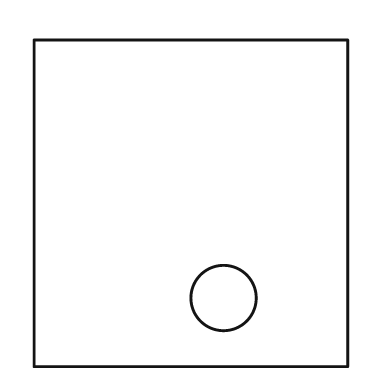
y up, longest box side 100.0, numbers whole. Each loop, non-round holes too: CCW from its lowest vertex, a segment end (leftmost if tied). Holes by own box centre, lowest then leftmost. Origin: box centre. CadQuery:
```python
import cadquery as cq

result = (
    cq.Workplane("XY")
    .moveTo(-48.0, -50.0)
    .lineTo(48.0, -50.0)
    .lineTo(48.0, 50.0)
    .lineTo(-48.0, 50.0)
    .close()
    .moveTo(10.0, -29.0)
    .circle(10.0)
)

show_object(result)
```